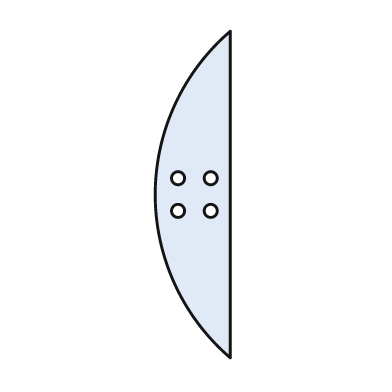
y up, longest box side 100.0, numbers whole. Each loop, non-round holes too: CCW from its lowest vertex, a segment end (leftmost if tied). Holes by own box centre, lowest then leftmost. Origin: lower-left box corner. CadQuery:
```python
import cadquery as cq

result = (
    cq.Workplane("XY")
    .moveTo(23.0, 0.0)
    .lineTo(23.0, 100.0)
    .threePointArc((0.0, 50.0), (23.0, 0.0))
    .close()
    .moveTo(7.0, 45.0)
    .circle(2.0)
    .moveTo(17.0, 45.0)
    .circle(2.0)
    .moveTo(7.0, 55.0)
    .circle(2.0)
    .moveTo(17.0, 55.0)
    .circle(2.0)
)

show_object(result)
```